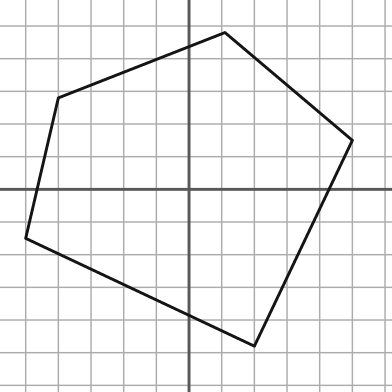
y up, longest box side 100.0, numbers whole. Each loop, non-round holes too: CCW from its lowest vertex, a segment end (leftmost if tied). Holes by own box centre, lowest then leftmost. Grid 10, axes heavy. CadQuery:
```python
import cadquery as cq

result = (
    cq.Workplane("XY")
    .moveTo(20.0, -48.0)
    .lineTo(50.0, 15.0)
    .lineTo(11.0, 48.0)
    .lineTo(-40.0, 28.0)
    .lineTo(-50.0, -15.0)
    .close()
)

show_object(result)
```